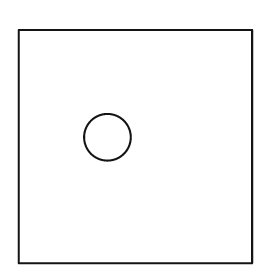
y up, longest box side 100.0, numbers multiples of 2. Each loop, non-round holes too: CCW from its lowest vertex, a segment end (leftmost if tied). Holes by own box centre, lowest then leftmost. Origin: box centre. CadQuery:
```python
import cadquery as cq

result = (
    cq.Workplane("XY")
    .moveTo(-50.0, -50.0)
    .lineTo(50.0, -50.0)
    .lineTo(50.0, 50.0)
    .lineTo(-50.0, 50.0)
    .close()
    .moveTo(-12.0, 4.0)
    .circle(10.0)
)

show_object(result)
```